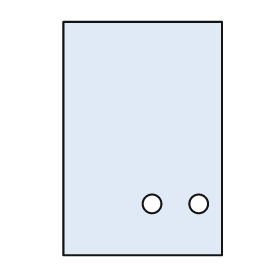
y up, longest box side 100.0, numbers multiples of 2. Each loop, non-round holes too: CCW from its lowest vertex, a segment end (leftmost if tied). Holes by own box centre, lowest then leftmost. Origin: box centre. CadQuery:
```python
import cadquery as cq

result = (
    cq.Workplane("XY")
    .moveTo(-34.0, -50.0)
    .lineTo(34.0, -50.0)
    .lineTo(34.0, 50.0)
    .lineTo(-34.0, 50.0)
    .close()
    .moveTo(4.0, -28.0)
    .circle(4.0)
    .moveTo(24.0, -28.0)
    .circle(4.0)
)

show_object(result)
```